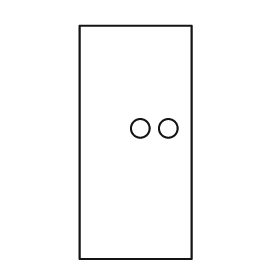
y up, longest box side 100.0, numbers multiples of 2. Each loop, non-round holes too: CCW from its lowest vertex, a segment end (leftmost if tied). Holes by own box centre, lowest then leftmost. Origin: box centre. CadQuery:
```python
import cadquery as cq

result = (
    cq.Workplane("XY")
    .moveTo(-24.0, -50.0)
    .lineTo(24.0, -50.0)
    .lineTo(24.0, 50.0)
    .lineTo(-24.0, 50.0)
    .close()
    .moveTo(2.0, 6.0)
    .circle(4.0)
    .moveTo(14.0, 6.0)
    .circle(4.0)
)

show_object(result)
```